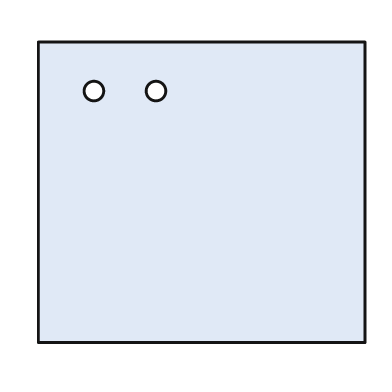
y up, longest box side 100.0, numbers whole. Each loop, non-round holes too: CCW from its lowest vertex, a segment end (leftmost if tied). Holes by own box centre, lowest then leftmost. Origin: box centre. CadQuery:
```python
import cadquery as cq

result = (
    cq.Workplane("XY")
    .moveTo(-50.0, -46.0)
    .lineTo(50.0, -46.0)
    .lineTo(50.0, 46.0)
    .lineTo(-50.0, 46.0)
    .close()
    .moveTo(-33.0, 31.0)
    .circle(3.0)
    .moveTo(-14.0, 31.0)
    .circle(3.0)
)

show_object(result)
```